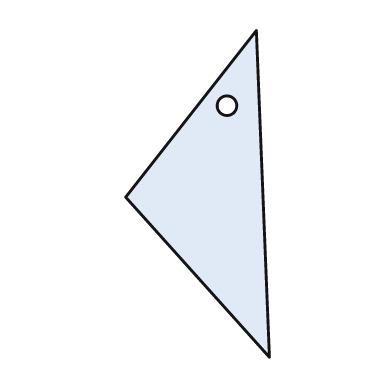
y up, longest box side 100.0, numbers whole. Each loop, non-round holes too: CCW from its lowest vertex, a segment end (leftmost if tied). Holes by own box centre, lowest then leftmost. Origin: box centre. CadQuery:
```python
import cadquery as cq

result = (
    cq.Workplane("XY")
    .moveTo(22.0, -50.0)
    .lineTo(18.0, 50.0)
    .lineTo(-22.0, -1.0)
    .close()
    .moveTo(9.0, 27.0)
    .circle(3.0)
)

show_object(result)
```